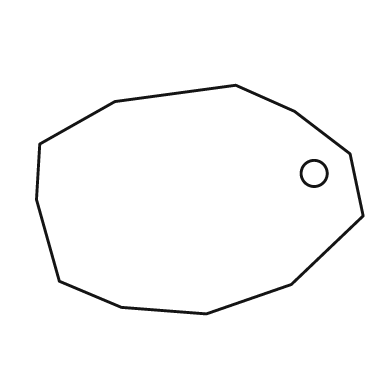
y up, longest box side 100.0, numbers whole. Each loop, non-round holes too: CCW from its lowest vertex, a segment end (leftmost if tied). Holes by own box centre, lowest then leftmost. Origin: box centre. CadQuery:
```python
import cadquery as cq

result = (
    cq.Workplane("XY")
    .moveTo(2.0, -35.0)
    .lineTo(28.0, -26.0)
    .lineTo(50.0, -5.0)
    .lineTo(46.0, 14.0)
    .lineTo(29.0, 27.0)
    .lineTo(11.0, 35.0)
    .lineTo(-26.0, 30.0)
    .lineTo(-49.0, 17.0)
    .lineTo(-50.0, 0.0)
    .lineTo(-43.0, -25.0)
    .lineTo(-24.0, -33.0)
    .close()
    .moveTo(35.0, 8.0)
    .circle(4.0)
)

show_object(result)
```